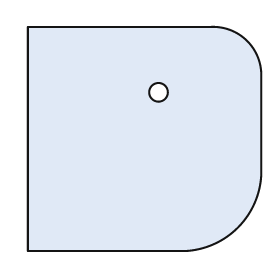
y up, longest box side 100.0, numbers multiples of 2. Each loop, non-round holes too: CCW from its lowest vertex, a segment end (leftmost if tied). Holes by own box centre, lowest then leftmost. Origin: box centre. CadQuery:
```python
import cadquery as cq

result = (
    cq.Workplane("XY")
    .moveTo(-50.0, -48.0)
    .lineTo(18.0, -48.0)
    .threePointArc((40.0, -38.0), (50.0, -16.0))
    .lineTo(50.0, 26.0)
    .threePointArc((44.0, 42.0), (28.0, 48.0))
    .lineTo(-50.0, 48.0)
    .close()
    .moveTo(6.0, 20.0)
    .circle(4.0)
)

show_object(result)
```